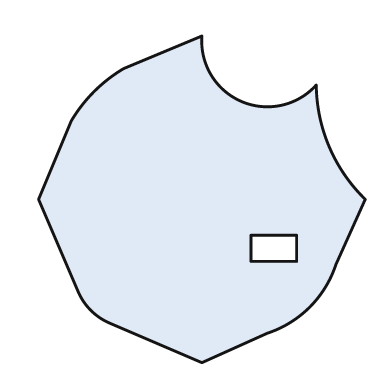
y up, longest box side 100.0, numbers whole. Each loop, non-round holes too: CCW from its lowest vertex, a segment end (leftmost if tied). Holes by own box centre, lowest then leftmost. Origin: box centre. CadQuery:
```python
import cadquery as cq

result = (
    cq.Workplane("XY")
    .moveTo(0.0, -50.0)
    .lineTo(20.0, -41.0)
    .threePointArc((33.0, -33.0), (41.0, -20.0))
    .lineTo(50.0, 0.0)
    .threePointArc((39.0, 16.0), (35.0, 35.0))
    .threePointArc((12.0, 30.0), (0.0, 50.0))
    .lineTo(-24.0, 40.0)
    .threePointArc((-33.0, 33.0), (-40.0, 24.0))
    .lineTo(-50.0, 0.0)
    .lineTo(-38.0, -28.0)
    .threePointArc((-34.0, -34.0), (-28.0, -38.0))
    .close()
    .moveTo(15.0, -19.0)
    .lineTo(29.0, -19.0)
    .lineTo(29.0, -11.0)
    .lineTo(15.0, -11.0)
    .close()
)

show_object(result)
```